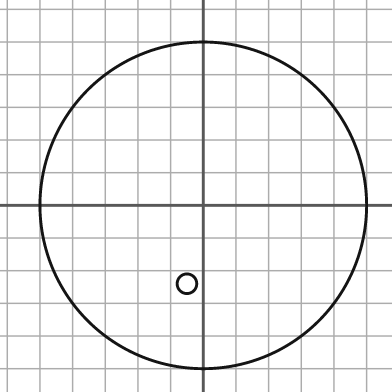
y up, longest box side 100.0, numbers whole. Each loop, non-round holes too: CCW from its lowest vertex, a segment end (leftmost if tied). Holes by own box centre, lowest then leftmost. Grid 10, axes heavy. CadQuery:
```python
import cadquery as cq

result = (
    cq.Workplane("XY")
    .moveTo(0.0, 0.0)
    .circle(50.0)
    .moveTo(-5.0, -24.0)
    .circle(3.0)
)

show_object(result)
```